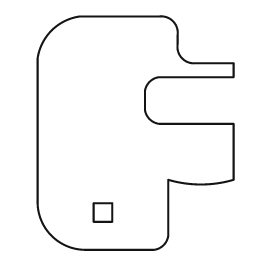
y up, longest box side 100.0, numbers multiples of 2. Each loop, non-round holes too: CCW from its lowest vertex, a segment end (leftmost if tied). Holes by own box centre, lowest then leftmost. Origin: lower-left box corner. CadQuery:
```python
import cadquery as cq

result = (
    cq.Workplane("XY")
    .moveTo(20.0, 0.0)
    .lineTo(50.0, 0.0)
    .threePointArc((54.0, 2.0), (56.0, 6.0))
    .lineTo(56.0, 30.0)
    .threePointArc((70.0, 28.0), (84.0, 30.0))
    .lineTo(84.0, 54.0)
    .lineTo(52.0, 54.0)
    .threePointArc((48.0, 56.0), (46.0, 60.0))
    .lineTo(46.0, 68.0)
    .threePointArc((48.0, 72.0), (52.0, 74.0))
    .lineTo(84.0, 74.0)
    .lineTo(84.0, 80.0)
    .lineTo(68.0, 80.0)
    .threePointArc((62.0, 82.0), (60.0, 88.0))
    .lineTo(60.0, 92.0)
    .threePointArc((58.0, 98.0), (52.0, 100.0))
    .lineTo(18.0, 100.0)
    .threePointArc((6.0, 94.0), (0.0, 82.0))
    .lineTo(0.0, 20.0)
    .threePointArc((6.0, 6.0), (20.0, 0.0))
    .close()
    .moveTo(24.0, 12.0)
    .lineTo(32.0, 12.0)
    .lineTo(32.0, 20.0)
    .lineTo(24.0, 20.0)
    .close()
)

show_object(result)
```